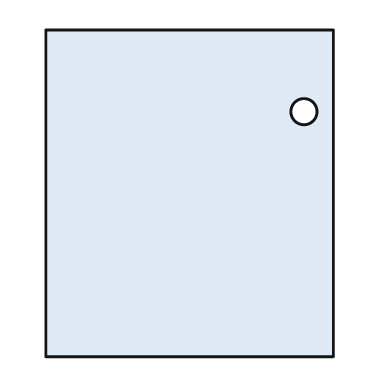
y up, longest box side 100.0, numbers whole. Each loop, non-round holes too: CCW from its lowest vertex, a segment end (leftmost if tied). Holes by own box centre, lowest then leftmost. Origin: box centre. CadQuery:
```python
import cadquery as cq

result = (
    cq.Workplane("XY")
    .moveTo(-44.0, -50.0)
    .lineTo(44.0, -50.0)
    .lineTo(44.0, 50.0)
    .lineTo(-44.0, 50.0)
    .close()
    .moveTo(35.0, 25.0)
    .circle(4.0)
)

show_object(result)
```